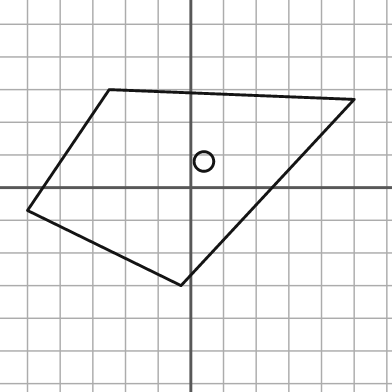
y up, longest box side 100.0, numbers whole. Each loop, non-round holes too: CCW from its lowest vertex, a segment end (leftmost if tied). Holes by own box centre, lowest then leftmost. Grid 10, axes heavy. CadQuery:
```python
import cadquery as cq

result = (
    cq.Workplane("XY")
    .moveTo(-3.0, -30.0)
    .lineTo(50.0, 27.0)
    .lineTo(-25.0, 30.0)
    .lineTo(-50.0, -7.0)
    .close()
    .moveTo(4.0, 8.0)
    .circle(3.0)
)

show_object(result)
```